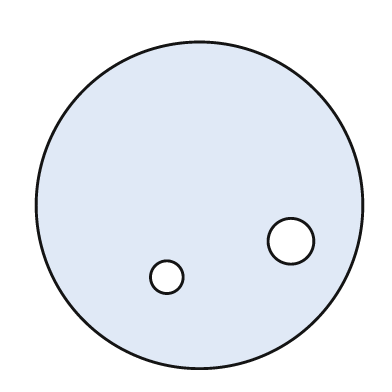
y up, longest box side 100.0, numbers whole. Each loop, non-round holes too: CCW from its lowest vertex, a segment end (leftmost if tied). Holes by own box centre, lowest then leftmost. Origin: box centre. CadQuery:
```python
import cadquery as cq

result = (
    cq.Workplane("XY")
    .moveTo(0.0, 0.0)
    .circle(50.0)
    .moveTo(-10.0, -22.0)
    .circle(5.0)
    .moveTo(28.0, -11.0)
    .circle(7.0)
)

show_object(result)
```